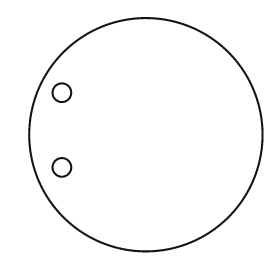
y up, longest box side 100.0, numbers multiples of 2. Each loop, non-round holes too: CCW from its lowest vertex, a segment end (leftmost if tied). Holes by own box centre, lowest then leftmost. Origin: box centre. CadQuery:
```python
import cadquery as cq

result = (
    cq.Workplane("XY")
    .moveTo(0.0, 0.0)
    .circle(50.0)
    .moveTo(-36.0, -14.0)
    .circle(4.0)
    .moveTo(-36.0, 18.0)
    .circle(4.0)
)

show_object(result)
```